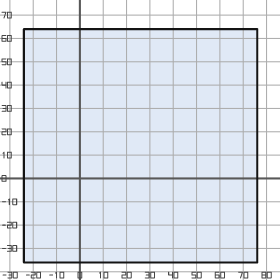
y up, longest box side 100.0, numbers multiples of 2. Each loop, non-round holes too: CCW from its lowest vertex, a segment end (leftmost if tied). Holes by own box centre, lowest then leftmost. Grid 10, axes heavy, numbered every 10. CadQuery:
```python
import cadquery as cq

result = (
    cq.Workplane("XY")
    .moveTo(-24.0, -36.0)
    .lineTo(76.0, -36.0)
    .lineTo(76.0, 64.0)
    .lineTo(-24.0, 64.0)
    .close()
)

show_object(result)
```